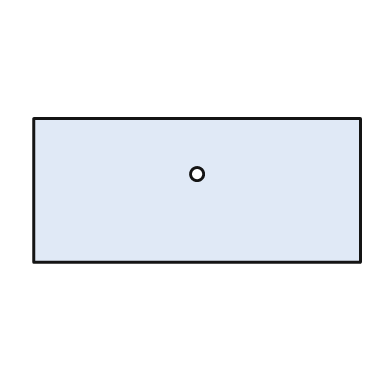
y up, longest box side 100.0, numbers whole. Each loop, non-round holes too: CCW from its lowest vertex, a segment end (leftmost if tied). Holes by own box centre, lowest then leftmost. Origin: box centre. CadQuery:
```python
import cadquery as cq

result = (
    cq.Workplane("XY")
    .moveTo(-50.0, -22.0)
    .lineTo(50.0, -22.0)
    .lineTo(50.0, 22.0)
    .lineTo(-50.0, 22.0)
    .close()
    .moveTo(0.0, 5.0)
    .circle(2.0)
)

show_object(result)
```